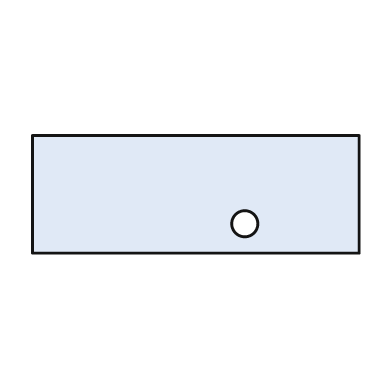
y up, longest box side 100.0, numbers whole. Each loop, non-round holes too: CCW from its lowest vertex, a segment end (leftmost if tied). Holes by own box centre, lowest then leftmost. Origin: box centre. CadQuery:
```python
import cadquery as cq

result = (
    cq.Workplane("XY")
    .moveTo(-50.0, -18.0)
    .lineTo(50.0, -18.0)
    .lineTo(50.0, 18.0)
    .lineTo(-50.0, 18.0)
    .close()
    .moveTo(15.0, -9.0)
    .circle(4.0)
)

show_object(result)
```